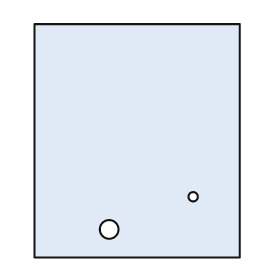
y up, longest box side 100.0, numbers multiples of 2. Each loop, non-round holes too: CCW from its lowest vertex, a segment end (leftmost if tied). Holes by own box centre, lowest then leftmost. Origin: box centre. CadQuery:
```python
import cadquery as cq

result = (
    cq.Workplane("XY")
    .moveTo(-44.0, -50.0)
    .lineTo(44.0, -50.0)
    .lineTo(44.0, 50.0)
    .lineTo(-44.0, 50.0)
    .close()
    .moveTo(-12.0, -38.0)
    .circle(4.0)
    .moveTo(24.0, -24.0)
    .circle(2.0)
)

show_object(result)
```